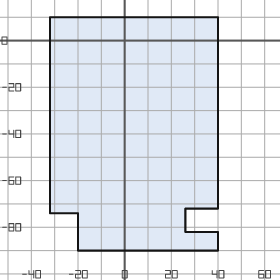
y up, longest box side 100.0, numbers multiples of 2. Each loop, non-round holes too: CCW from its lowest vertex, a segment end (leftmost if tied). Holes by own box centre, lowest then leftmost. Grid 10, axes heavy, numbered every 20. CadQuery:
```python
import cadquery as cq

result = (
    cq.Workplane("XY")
    .moveTo(-20.0, -90.0)
    .lineTo(40.0, -90.0)
    .lineTo(40.0, -82.0)
    .lineTo(26.0, -82.0)
    .lineTo(26.0, -72.0)
    .lineTo(40.0, -72.0)
    .lineTo(40.0, 10.0)
    .lineTo(-32.0, 10.0)
    .lineTo(-32.0, -74.0)
    .lineTo(-20.0, -74.0)
    .close()
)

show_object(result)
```